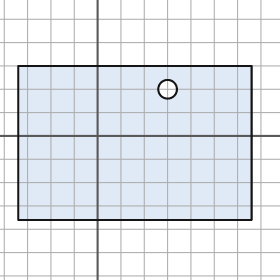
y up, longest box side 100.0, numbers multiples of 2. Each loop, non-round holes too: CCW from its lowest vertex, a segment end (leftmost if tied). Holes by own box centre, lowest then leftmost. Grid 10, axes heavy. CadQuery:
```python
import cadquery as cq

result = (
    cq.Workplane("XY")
    .moveTo(-34.0, -36.0)
    .lineTo(66.0, -36.0)
    .lineTo(66.0, 30.0)
    .lineTo(-34.0, 30.0)
    .close()
    .moveTo(30.0, 20.0)
    .circle(4.0)
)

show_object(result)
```